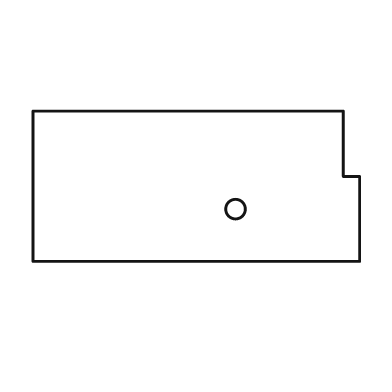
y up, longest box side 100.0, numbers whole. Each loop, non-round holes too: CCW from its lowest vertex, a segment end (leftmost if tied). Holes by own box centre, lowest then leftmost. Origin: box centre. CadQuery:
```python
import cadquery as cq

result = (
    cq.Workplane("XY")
    .moveTo(-50.0, -23.0)
    .lineTo(50.0, -23.0)
    .lineTo(50.0, 3.0)
    .lineTo(45.0, 3.0)
    .lineTo(45.0, 23.0)
    .lineTo(-50.0, 23.0)
    .close()
    .moveTo(12.0, -7.0)
    .circle(3.0)
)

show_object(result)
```